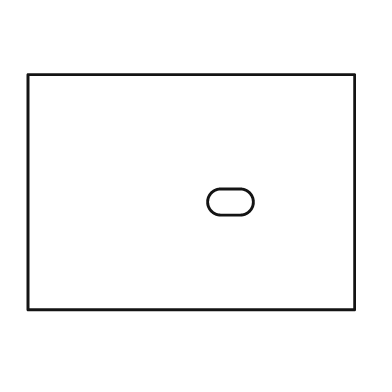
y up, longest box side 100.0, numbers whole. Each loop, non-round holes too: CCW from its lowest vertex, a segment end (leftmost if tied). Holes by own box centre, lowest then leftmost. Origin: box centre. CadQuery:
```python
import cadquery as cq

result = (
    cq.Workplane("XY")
    .moveTo(-50.0, -36.0)
    .lineTo(50.0, -36.0)
    .lineTo(50.0, 36.0)
    .lineTo(-50.0, 36.0)
    .close()
    .moveTo(9.0, -7.0)
    .lineTo(15.0, -7.0)
    .threePointArc((19.0, -3.0), (15.0, 1.0))
    .lineTo(9.0, 1.0)
    .threePointArc((5.0, -3.0), (9.0, -7.0))
    .close()
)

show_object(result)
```